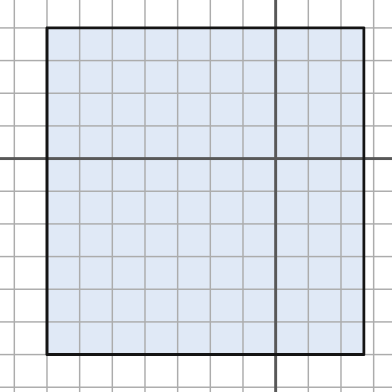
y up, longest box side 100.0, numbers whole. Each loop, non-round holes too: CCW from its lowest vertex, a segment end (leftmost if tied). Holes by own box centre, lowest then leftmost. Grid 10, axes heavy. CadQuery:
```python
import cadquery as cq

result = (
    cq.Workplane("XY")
    .moveTo(-70.0, -60.0)
    .lineTo(27.0, -60.0)
    .lineTo(27.0, 40.0)
    .lineTo(-70.0, 40.0)
    .close()
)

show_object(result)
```